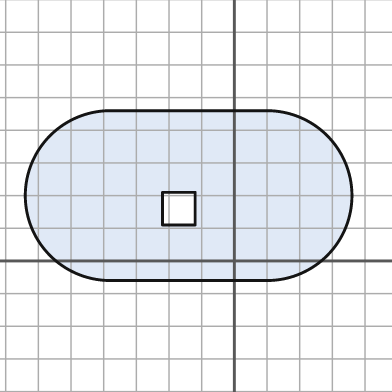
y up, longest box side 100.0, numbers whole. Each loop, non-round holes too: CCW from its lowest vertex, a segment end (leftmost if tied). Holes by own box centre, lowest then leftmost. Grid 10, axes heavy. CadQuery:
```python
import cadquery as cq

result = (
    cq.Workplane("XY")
    .moveTo(-38.0, -6.0)
    .lineTo(10.0, -6.0)
    .threePointArc((36.0, 20.0), (10.0, 46.0))
    .lineTo(-38.0, 46.0)
    .threePointArc((-64.0, 20.0), (-38.0, -6.0))
    .close()
    .moveTo(-22.0, 11.0)
    .lineTo(-12.0, 11.0)
    .lineTo(-12.0, 21.0)
    .lineTo(-22.0, 21.0)
    .close()
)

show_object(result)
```